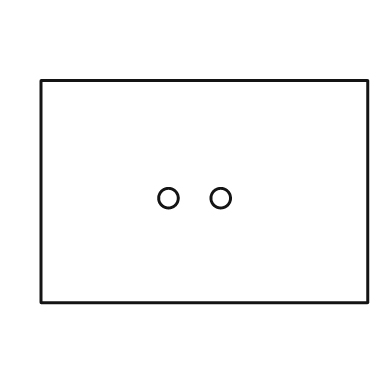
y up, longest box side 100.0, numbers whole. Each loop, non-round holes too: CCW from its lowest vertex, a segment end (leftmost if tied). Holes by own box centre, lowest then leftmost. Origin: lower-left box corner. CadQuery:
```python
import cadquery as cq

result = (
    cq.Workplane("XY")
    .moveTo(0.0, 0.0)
    .lineTo(100.0, 0.0)
    .lineTo(100.0, 68.0)
    .lineTo(0.0, 68.0)
    .close()
    .moveTo(39.0, 32.0)
    .circle(3.0)
    .moveTo(55.0, 32.0)
    .circle(3.0)
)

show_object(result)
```